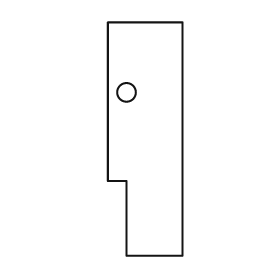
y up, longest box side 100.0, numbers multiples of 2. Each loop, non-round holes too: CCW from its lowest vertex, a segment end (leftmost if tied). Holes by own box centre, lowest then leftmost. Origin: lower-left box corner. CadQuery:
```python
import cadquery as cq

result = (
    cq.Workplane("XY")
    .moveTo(8.0, 0.0)
    .lineTo(32.0, 0.0)
    .lineTo(32.0, 100.0)
    .lineTo(0.0, 100.0)
    .lineTo(0.0, 32.0)
    .lineTo(8.0, 32.0)
    .close()
    .moveTo(8.0, 70.0)
    .circle(4.0)
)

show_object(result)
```